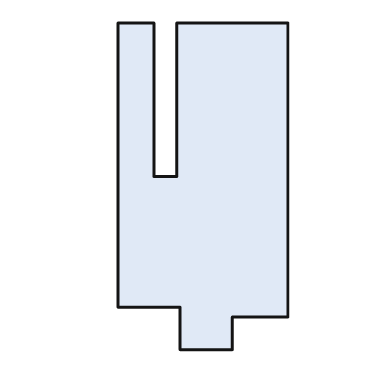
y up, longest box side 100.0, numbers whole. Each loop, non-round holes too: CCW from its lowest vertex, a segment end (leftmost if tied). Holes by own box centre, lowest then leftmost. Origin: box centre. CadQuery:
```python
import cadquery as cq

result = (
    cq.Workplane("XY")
    .moveTo(-7.0, -50.0)
    .lineTo(9.0, -50.0)
    .lineTo(9.0, -40.0)
    .lineTo(26.0, -40.0)
    .lineTo(26.0, 50.0)
    .lineTo(-8.0, 50.0)
    .lineTo(-8.0, 3.0)
    .lineTo(-15.0, 3.0)
    .lineTo(-15.0, 50.0)
    .lineTo(-26.0, 50.0)
    .lineTo(-26.0, -37.0)
    .lineTo(-7.0, -37.0)
    .close()
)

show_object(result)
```